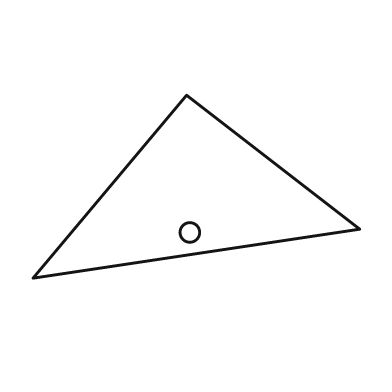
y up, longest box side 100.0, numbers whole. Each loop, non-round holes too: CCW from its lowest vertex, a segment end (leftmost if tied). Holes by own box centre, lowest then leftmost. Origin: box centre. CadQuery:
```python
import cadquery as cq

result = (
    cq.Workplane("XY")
    .moveTo(-50.0, -28.0)
    .lineTo(50.0, -13.0)
    .lineTo(-3.0, 28.0)
    .close()
    .moveTo(-2.0, -14.0)
    .circle(3.0)
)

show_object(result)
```